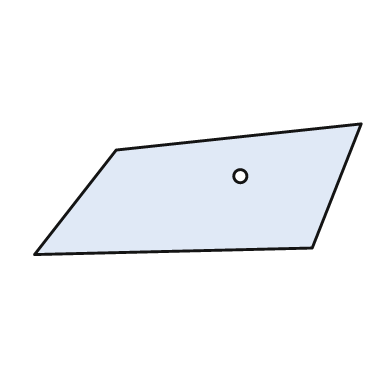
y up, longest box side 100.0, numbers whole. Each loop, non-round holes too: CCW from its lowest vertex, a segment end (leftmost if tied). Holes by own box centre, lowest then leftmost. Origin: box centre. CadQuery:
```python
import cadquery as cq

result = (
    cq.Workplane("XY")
    .moveTo(-50.0, -20.0)
    .lineTo(35.0, -18.0)
    .lineTo(50.0, 20.0)
    .lineTo(-25.0, 12.0)
    .close()
    .moveTo(13.0, 4.0)
    .circle(2.0)
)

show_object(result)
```